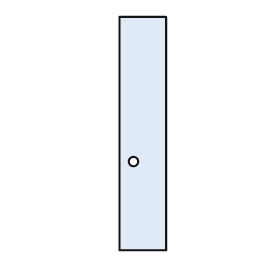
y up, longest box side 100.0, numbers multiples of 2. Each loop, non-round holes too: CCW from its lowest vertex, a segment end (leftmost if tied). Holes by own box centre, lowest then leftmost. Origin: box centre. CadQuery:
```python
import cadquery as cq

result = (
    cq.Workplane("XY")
    .moveTo(-10.0, -50.0)
    .lineTo(10.0, -50.0)
    .lineTo(10.0, 50.0)
    .lineTo(-10.0, 50.0)
    .close()
    .moveTo(-4.0, -12.0)
    .circle(2.0)
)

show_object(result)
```